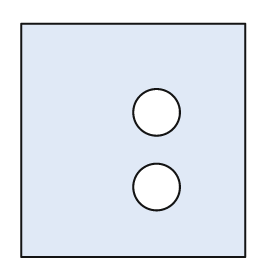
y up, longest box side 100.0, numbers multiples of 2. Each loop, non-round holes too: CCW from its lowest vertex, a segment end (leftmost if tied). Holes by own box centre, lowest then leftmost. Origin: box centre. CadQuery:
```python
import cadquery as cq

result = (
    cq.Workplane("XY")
    .moveTo(-48.0, -50.0)
    .lineTo(48.0, -50.0)
    .lineTo(48.0, 50.0)
    .lineTo(-48.0, 50.0)
    .close()
    .moveTo(10.0, -20.0)
    .circle(10.0)
    .moveTo(10.0, 12.0)
    .circle(10.0)
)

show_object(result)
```